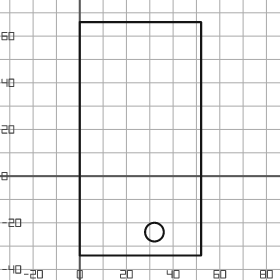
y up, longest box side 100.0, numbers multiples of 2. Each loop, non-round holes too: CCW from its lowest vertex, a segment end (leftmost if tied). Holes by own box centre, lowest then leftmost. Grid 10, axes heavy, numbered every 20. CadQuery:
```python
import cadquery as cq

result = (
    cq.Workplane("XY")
    .moveTo(0.0, -34.0)
    .lineTo(52.0, -34.0)
    .lineTo(52.0, 66.0)
    .lineTo(0.0, 66.0)
    .close()
    .moveTo(32.0, -24.0)
    .circle(4.0)
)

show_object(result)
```